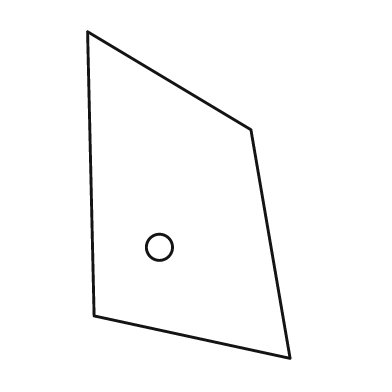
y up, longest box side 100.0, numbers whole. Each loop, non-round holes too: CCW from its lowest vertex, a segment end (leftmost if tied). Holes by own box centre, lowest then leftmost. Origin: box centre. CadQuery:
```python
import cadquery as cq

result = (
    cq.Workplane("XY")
    .moveTo(31.0, -50.0)
    .lineTo(19.0, 20.0)
    .lineTo(-31.0, 50.0)
    .lineTo(-29.0, -37.0)
    .close()
    .moveTo(-9.0, -16.0)
    .circle(4.0)
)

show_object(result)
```